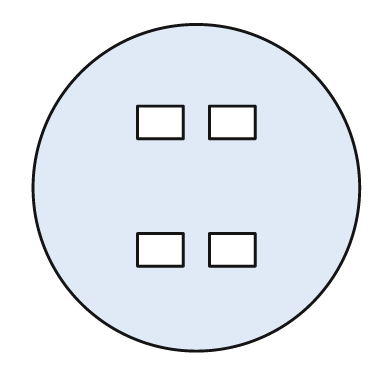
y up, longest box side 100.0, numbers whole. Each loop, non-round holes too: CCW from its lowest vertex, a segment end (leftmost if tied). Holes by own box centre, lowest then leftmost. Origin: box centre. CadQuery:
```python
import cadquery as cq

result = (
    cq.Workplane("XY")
    .moveTo(0.0, 0.0)
    .circle(50.0)
    .moveTo(-18.0, -24.0)
    .lineTo(-4.0, -24.0)
    .lineTo(-4.0, -14.0)
    .lineTo(-18.0, -14.0)
    .close()
    .moveTo(4.0, -24.0)
    .lineTo(18.0, -24.0)
    .lineTo(18.0, -14.0)
    .lineTo(4.0, -14.0)
    .close()
    .moveTo(-18.0, 15.0)
    .lineTo(-4.0, 15.0)
    .lineTo(-4.0, 25.0)
    .lineTo(-18.0, 25.0)
    .close()
    .moveTo(4.0, 15.0)
    .lineTo(18.0, 15.0)
    .lineTo(18.0, 25.0)
    .lineTo(4.0, 25.0)
    .close()
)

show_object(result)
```